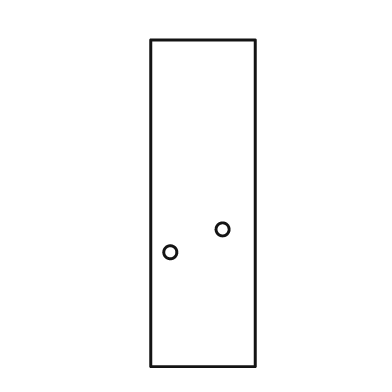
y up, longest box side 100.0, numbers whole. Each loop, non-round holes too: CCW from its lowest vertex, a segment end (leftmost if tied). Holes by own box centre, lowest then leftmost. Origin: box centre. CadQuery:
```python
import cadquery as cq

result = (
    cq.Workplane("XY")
    .moveTo(-16.0, -50.0)
    .lineTo(16.0, -50.0)
    .lineTo(16.0, 50.0)
    .lineTo(-16.0, 50.0)
    .close()
    .moveTo(-10.0, -15.0)
    .circle(2.0)
    .moveTo(6.0, -8.0)
    .circle(2.0)
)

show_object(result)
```